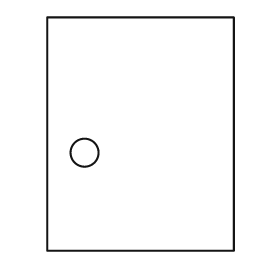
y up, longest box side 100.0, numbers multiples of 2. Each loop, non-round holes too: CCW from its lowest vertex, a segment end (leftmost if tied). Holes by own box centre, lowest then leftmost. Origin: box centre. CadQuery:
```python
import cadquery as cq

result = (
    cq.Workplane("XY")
    .moveTo(-40.0, -50.0)
    .lineTo(40.0, -50.0)
    .lineTo(40.0, 50.0)
    .lineTo(-40.0, 50.0)
    .close()
    .moveTo(-24.0, -8.0)
    .circle(6.0)
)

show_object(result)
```